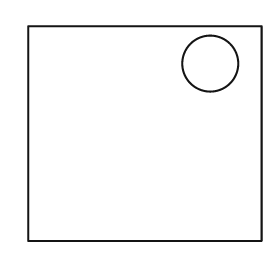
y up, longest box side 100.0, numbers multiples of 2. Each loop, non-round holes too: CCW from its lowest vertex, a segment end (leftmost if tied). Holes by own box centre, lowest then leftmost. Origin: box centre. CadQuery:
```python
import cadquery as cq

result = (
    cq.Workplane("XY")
    .moveTo(-50.0, -46.0)
    .lineTo(50.0, -46.0)
    .lineTo(50.0, 46.0)
    .lineTo(-50.0, 46.0)
    .close()
    .moveTo(28.0, 30.0)
    .circle(12.0)
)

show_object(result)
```